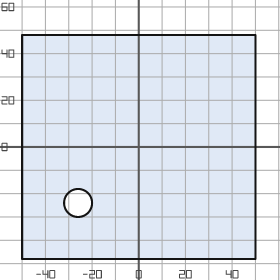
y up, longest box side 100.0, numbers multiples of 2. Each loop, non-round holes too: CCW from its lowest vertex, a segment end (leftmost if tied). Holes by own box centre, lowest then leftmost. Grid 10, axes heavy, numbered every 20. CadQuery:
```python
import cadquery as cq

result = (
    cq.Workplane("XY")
    .moveTo(-50.0, -48.0)
    .lineTo(50.0, -48.0)
    .lineTo(50.0, 48.0)
    .lineTo(-50.0, 48.0)
    .close()
    .moveTo(-26.0, -24.0)
    .circle(6.0)
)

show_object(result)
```